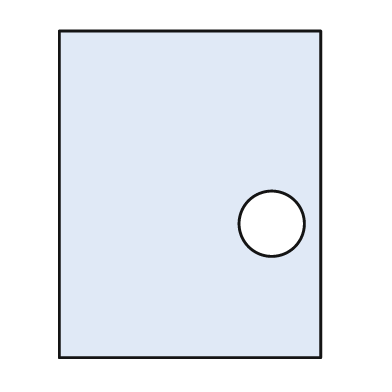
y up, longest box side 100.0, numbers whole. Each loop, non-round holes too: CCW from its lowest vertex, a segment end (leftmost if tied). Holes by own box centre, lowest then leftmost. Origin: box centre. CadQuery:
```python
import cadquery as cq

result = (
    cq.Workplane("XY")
    .moveTo(-40.0, -50.0)
    .lineTo(40.0, -50.0)
    .lineTo(40.0, 50.0)
    .lineTo(-40.0, 50.0)
    .close()
    .moveTo(25.0, -9.0)
    .circle(10.0)
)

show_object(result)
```